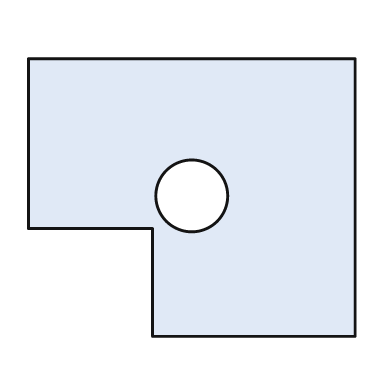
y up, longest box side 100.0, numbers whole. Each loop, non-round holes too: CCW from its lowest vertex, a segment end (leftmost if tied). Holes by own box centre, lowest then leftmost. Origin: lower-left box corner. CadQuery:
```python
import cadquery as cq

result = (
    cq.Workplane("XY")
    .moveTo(38.0, 0.0)
    .lineTo(100.0, 0.0)
    .lineTo(100.0, 85.0)
    .lineTo(0.0, 85.0)
    .lineTo(0.0, 33.0)
    .lineTo(38.0, 33.0)
    .close()
    .moveTo(50.0, 43.0)
    .circle(11.0)
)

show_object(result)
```